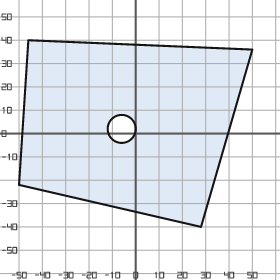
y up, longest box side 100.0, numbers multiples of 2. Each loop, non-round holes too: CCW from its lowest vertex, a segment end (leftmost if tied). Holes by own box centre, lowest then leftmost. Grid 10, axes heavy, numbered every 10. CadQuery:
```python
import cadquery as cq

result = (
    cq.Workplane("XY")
    .moveTo(28.0, -40.0)
    .lineTo(50.0, 36.0)
    .lineTo(-46.0, 40.0)
    .lineTo(-50.0, -22.0)
    .close()
    .moveTo(-6.0, 2.0)
    .circle(6.0)
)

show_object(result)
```